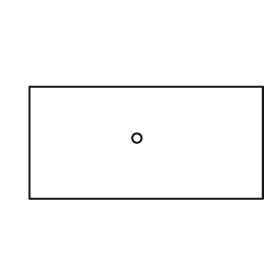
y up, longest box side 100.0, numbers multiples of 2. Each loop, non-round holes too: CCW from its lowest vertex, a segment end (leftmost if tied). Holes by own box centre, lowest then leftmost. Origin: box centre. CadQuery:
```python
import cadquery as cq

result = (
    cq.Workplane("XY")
    .moveTo(-50.0, -24.0)
    .lineTo(50.0, -24.0)
    .lineTo(50.0, 24.0)
    .lineTo(-50.0, 24.0)
    .close()
    .moveTo(-4.0, 2.0)
    .circle(2.0)
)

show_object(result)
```